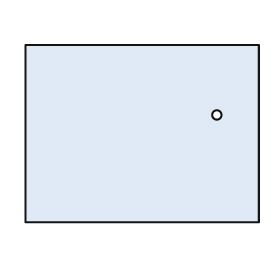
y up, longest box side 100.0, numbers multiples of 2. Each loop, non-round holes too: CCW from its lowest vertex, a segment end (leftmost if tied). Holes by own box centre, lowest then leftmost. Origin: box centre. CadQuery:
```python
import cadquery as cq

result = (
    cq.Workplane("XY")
    .moveTo(-50.0, -38.0)
    .lineTo(50.0, -38.0)
    .lineTo(50.0, 38.0)
    .lineTo(-50.0, 38.0)
    .close()
    .moveTo(32.0, 8.0)
    .circle(2.0)
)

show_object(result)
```